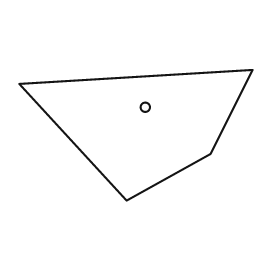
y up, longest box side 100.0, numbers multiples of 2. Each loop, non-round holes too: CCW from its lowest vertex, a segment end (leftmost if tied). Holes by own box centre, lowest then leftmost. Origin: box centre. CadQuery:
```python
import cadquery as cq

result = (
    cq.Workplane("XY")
    .moveTo(-4.0, -28.0)
    .lineTo(32.0, -8.0)
    .lineTo(50.0, 28.0)
    .lineTo(-50.0, 22.0)
    .close()
    .moveTo(4.0, 12.0)
    .circle(2.0)
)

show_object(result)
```